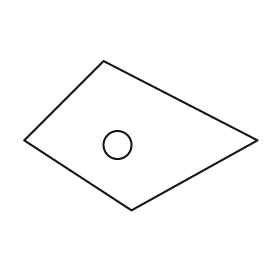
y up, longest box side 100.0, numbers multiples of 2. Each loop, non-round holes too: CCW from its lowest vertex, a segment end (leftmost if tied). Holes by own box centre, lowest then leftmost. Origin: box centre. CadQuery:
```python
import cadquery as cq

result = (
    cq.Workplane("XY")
    .moveTo(-4.0, -32.0)
    .lineTo(50.0, -2.0)
    .lineTo(-16.0, 32.0)
    .lineTo(-50.0, -2.0)
    .close()
    .moveTo(-10.0, -4.0)
    .circle(6.0)
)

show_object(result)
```